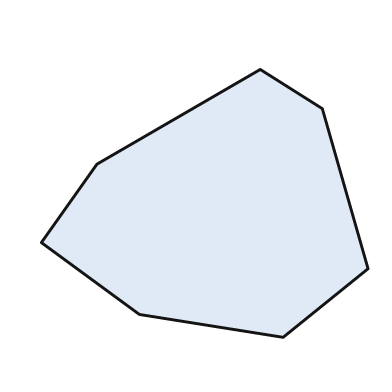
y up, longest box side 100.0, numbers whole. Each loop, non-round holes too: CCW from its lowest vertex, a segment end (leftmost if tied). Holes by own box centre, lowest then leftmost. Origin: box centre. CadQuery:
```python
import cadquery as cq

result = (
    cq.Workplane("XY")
    .moveTo(24.0, -41.0)
    .lineTo(50.0, -20.0)
    .lineTo(36.0, 29.0)
    .lineTo(17.0, 41.0)
    .lineTo(-33.0, 12.0)
    .lineTo(-50.0, -12.0)
    .lineTo(-20.0, -34.0)
    .close()
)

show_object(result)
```